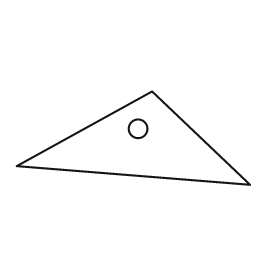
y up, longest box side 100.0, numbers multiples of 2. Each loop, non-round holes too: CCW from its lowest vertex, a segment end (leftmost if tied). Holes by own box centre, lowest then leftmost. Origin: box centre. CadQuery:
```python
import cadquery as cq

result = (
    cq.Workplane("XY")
    .moveTo(50.0, -20.0)
    .lineTo(8.0, 20.0)
    .lineTo(-50.0, -12.0)
    .close()
    .moveTo(2.0, 4.0)
    .circle(4.0)
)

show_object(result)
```